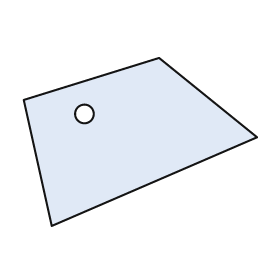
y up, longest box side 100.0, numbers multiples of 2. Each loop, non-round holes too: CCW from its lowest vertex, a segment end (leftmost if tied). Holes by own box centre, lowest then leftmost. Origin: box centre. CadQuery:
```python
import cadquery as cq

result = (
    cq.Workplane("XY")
    .moveTo(-38.0, -36.0)
    .lineTo(50.0, 2.0)
    .lineTo(8.0, 36.0)
    .lineTo(-50.0, 18.0)
    .close()
    .moveTo(-24.0, 12.0)
    .circle(4.0)
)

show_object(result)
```